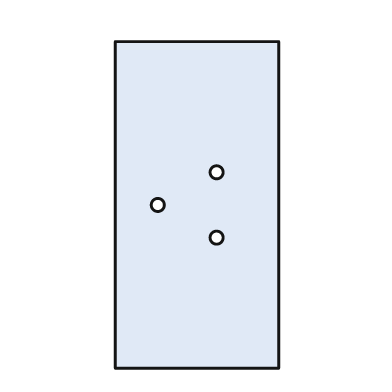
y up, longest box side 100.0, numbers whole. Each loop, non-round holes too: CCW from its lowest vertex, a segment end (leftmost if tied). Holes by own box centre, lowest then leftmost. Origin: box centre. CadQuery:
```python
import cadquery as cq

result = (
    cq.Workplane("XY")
    .moveTo(-25.0, -50.0)
    .lineTo(25.0, -50.0)
    .lineTo(25.0, 50.0)
    .lineTo(-25.0, 50.0)
    .close()
    .moveTo(6.0, -10.0)
    .circle(2.0)
    .moveTo(-12.0, 0.0)
    .circle(2.0)
    .moveTo(6.0, 10.0)
    .circle(2.0)
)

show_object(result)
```